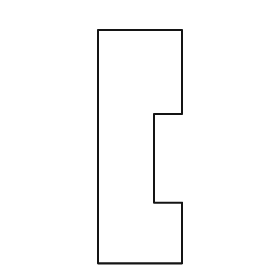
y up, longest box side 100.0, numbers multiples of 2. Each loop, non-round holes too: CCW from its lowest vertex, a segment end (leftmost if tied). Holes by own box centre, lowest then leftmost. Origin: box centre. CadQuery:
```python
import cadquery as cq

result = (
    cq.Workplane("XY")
    .moveTo(-18.0, -50.0)
    .lineTo(18.0, -50.0)
    .lineTo(18.0, -24.0)
    .lineTo(6.0, -24.0)
    .lineTo(6.0, 14.0)
    .lineTo(18.0, 14.0)
    .lineTo(18.0, 50.0)
    .lineTo(-18.0, 50.0)
    .close()
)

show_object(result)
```